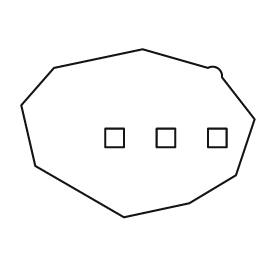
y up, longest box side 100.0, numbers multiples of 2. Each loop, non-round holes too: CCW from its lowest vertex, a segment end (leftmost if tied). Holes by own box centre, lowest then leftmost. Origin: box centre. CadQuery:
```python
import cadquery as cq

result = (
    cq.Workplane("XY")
    .moveTo(-6.0, -36.0)
    .lineTo(22.0, -30.0)
    .lineTo(42.0, -18.0)
    .lineTo(50.0, 6.0)
    .lineTo(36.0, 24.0)
    .threePointArc((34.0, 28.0), (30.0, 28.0))
    .lineTo(2.0, 36.0)
    .lineTo(-36.0, 28.0)
    .lineTo(-50.0, 12.0)
    .lineTo(-44.0, -14.0)
    .close()
    .moveTo(-14.0, -6.0)
    .lineTo(-6.0, -6.0)
    .lineTo(-6.0, 2.0)
    .lineTo(-14.0, 2.0)
    .close()
    .moveTo(8.0, -6.0)
    .lineTo(16.0, -6.0)
    .lineTo(16.0, 2.0)
    .lineTo(8.0, 2.0)
    .close()
    .moveTo(30.0, -6.0)
    .lineTo(38.0, -6.0)
    .lineTo(38.0, 2.0)
    .lineTo(30.0, 2.0)
    .close()
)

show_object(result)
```